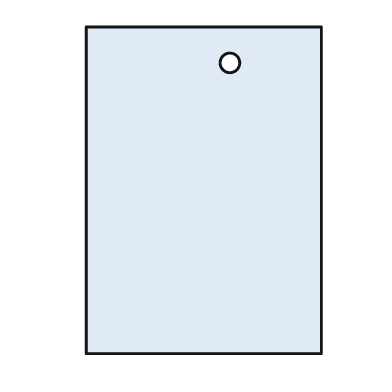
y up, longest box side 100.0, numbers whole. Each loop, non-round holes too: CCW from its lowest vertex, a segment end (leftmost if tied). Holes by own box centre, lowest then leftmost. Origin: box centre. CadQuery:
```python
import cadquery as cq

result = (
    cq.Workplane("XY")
    .moveTo(-36.0, -50.0)
    .lineTo(36.0, -50.0)
    .lineTo(36.0, 50.0)
    .lineTo(-36.0, 50.0)
    .close()
    .moveTo(8.0, 39.0)
    .circle(3.0)
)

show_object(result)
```